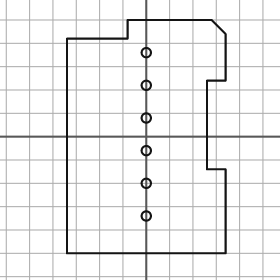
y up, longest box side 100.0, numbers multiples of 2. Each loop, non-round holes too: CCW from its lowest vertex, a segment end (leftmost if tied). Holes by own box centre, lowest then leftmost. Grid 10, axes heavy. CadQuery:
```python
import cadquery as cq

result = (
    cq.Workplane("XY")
    .moveTo(-34.0, -50.0)
    .lineTo(34.0, -50.0)
    .lineTo(34.0, -14.0)
    .lineTo(26.0, -14.0)
    .lineTo(26.0, 24.0)
    .lineTo(34.0, 24.0)
    .lineTo(34.0, 44.0)
    .lineTo(28.0, 50.0)
    .lineTo(-8.0, 50.0)
    .lineTo(-8.0, 42.0)
    .lineTo(-34.0, 42.0)
    .close()
    .moveTo(0.0, -34.0)
    .circle(2.0)
    .moveTo(0.0, -20.0)
    .circle(2.0)
    .moveTo(0.0, -6.0)
    .circle(2.0)
    .moveTo(0.0, 8.0)
    .circle(2.0)
    .moveTo(0.0, 22.0)
    .circle(2.0)
    .moveTo(0.0, 36.0)
    .circle(2.0)
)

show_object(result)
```